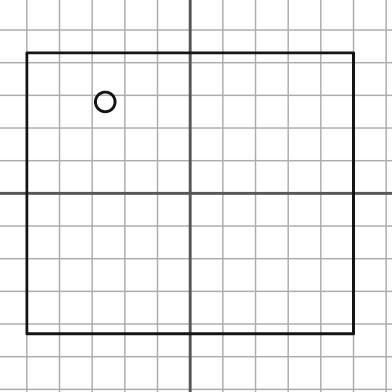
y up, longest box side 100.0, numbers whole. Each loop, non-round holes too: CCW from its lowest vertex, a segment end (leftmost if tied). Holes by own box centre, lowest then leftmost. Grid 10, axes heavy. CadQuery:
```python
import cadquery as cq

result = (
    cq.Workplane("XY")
    .moveTo(-50.0, -43.0)
    .lineTo(50.0, -43.0)
    .lineTo(50.0, 43.0)
    .lineTo(-50.0, 43.0)
    .close()
    .moveTo(-26.0, 28.0)
    .circle(3.0)
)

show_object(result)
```